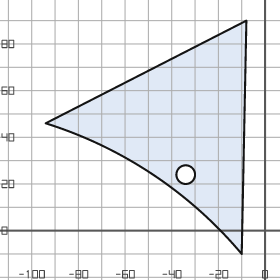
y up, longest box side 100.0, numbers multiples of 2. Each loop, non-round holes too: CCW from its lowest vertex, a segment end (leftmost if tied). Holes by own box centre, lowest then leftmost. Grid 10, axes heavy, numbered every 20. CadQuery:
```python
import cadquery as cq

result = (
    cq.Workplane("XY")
    .moveTo(-10.0, -10.0)
    .lineTo(-8.0, 90.0)
    .lineTo(-94.0, 46.0)
    .threePointArc((-48.0, 24.0), (-10.0, -10.0))
    .close()
    .moveTo(-34.0, 24.0)
    .circle(4.0)
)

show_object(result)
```